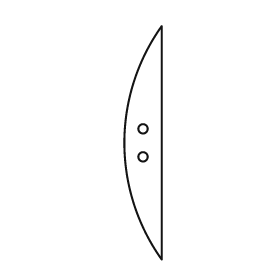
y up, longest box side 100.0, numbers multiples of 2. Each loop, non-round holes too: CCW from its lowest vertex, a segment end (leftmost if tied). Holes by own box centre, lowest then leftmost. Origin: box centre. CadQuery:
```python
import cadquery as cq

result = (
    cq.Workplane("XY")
    .moveTo(8.0, -50.0)
    .lineTo(8.0, 50.0)
    .threePointArc((-8.0, 0.0), (8.0, -50.0))
    .close()
    .moveTo(0.0, -6.0)
    .circle(2.0)
    .moveTo(0.0, 6.0)
    .circle(2.0)
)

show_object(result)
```